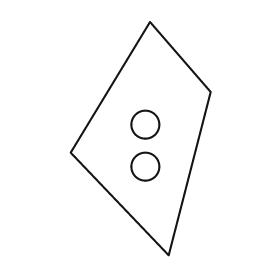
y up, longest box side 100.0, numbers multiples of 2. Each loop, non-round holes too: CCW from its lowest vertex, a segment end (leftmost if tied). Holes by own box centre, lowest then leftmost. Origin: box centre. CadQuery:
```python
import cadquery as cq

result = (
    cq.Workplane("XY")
    .moveTo(12.0, -50.0)
    .lineTo(30.0, 20.0)
    .lineTo(4.0, 50.0)
    .lineTo(-30.0, -6.0)
    .close()
    .moveTo(2.0, -12.0)
    .circle(6.0)
    .moveTo(2.0, 6.0)
    .circle(6.0)
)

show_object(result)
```